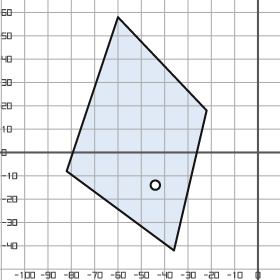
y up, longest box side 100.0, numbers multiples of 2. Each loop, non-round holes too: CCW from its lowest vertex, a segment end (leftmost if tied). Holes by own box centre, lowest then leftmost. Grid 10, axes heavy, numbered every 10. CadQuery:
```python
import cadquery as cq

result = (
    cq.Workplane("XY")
    .moveTo(-36.0, -42.0)
    .lineTo(-22.0, 18.0)
    .lineTo(-60.0, 58.0)
    .lineTo(-82.0, -8.0)
    .close()
    .moveTo(-44.0, -14.0)
    .circle(2.0)
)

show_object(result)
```